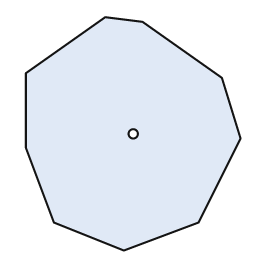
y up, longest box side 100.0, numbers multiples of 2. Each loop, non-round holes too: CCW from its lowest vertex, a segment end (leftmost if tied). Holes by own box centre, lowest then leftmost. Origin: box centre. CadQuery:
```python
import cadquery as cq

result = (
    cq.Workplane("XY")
    .moveTo(-4.0, -50.0)
    .lineTo(28.0, -38.0)
    .lineTo(46.0, -2.0)
    .lineTo(38.0, 24.0)
    .lineTo(4.0, 48.0)
    .lineTo(-12.0, 50.0)
    .lineTo(-46.0, 26.0)
    .lineTo(-46.0, -6.0)
    .lineTo(-34.0, -38.0)
    .close()
    .moveTo(0.0, 0.0)
    .circle(2.0)
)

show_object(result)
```